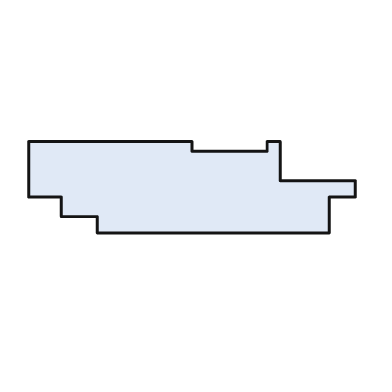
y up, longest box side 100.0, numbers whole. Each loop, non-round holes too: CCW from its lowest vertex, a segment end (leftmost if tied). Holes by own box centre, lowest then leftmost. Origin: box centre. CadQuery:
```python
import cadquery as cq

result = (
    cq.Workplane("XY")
    .moveTo(-29.0, -14.0)
    .lineTo(42.0, -14.0)
    .lineTo(42.0, -3.0)
    .lineTo(50.0, -3.0)
    .lineTo(50.0, 2.0)
    .lineTo(27.0, 2.0)
    .lineTo(27.0, 14.0)
    .lineTo(23.0, 14.0)
    .lineTo(23.0, 11.0)
    .lineTo(0.0, 11.0)
    .lineTo(0.0, 14.0)
    .lineTo(-50.0, 14.0)
    .lineTo(-50.0, -3.0)
    .lineTo(-40.0, -3.0)
    .lineTo(-40.0, -9.0)
    .lineTo(-29.0, -9.0)
    .close()
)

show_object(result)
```